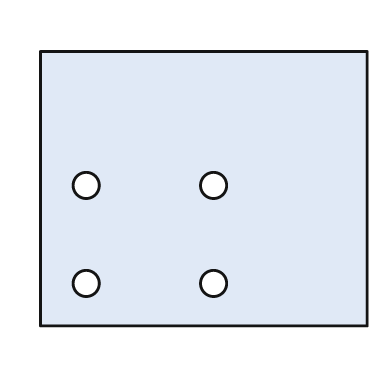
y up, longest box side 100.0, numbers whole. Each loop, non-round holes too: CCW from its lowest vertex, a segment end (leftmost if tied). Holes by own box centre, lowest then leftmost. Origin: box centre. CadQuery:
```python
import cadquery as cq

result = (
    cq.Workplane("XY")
    .moveTo(-50.0, -42.0)
    .lineTo(50.0, -42.0)
    .lineTo(50.0, 42.0)
    .lineTo(-50.0, 42.0)
    .close()
    .moveTo(-36.0, -29.0)
    .circle(4.0)
    .moveTo(3.0, -29.0)
    .circle(4.0)
    .moveTo(-36.0, 1.0)
    .circle(4.0)
    .moveTo(3.0, 1.0)
    .circle(4.0)
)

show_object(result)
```